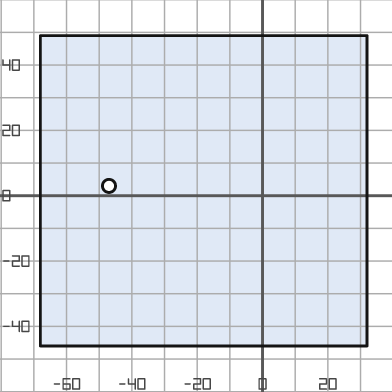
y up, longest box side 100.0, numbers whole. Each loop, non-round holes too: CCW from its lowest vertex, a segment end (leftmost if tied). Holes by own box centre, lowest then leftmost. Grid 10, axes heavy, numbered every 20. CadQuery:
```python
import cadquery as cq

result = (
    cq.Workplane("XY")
    .moveTo(-68.0, -46.0)
    .lineTo(32.0, -46.0)
    .lineTo(32.0, 49.0)
    .lineTo(-68.0, 49.0)
    .close()
    .moveTo(-47.0, 3.0)
    .circle(2.0)
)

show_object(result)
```